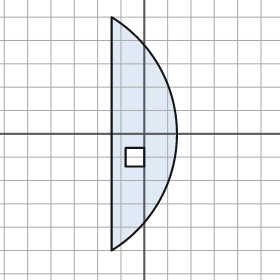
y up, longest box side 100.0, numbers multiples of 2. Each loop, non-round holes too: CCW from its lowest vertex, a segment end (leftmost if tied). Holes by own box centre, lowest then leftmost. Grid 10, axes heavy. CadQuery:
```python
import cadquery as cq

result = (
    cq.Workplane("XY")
    .moveTo(-14.0, -50.0)
    .threePointArc((14.0, 0.0), (-14.0, 50.0))
    .close()
    .moveTo(-8.0, -14.0)
    .lineTo(0.0, -14.0)
    .lineTo(0.0, -6.0)
    .lineTo(-8.0, -6.0)
    .close()
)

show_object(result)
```